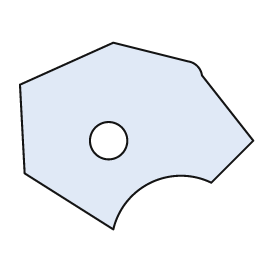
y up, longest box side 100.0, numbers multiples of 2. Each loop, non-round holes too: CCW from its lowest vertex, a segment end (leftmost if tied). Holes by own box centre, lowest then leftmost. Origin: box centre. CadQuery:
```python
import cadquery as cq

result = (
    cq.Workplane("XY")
    .moveTo(-10.0, -40.0)
    .threePointArc((6.0, -20.0), (32.0, -20.0))
    .lineTo(50.0, -2.0)
    .lineTo(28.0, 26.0)
    .threePointArc((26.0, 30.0), (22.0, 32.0))
    .lineTo(-10.0, 40.0)
    .lineTo(-50.0, 22.0)
    .lineTo(-48.0, -16.0)
    .close()
    .moveTo(-12.0, -2.0)
    .circle(8.0)
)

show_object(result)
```